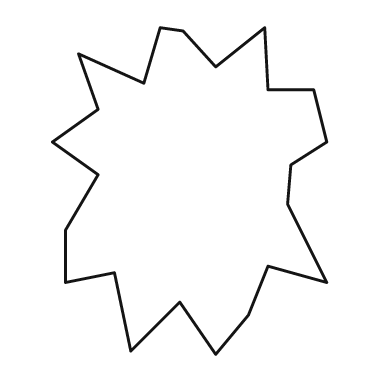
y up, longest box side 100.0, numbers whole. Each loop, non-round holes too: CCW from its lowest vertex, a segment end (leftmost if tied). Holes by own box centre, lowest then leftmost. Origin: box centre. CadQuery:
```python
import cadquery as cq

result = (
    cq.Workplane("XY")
    .moveTo(8.0, -50.0)
    .lineTo(18.0, -38.0)
    .lineTo(24.0, -23.0)
    .lineTo(42.0, -28.0)
    .lineTo(30.0, -4.0)
    .lineTo(31.0, 8.0)
    .lineTo(42.0, 15.0)
    .lineTo(38.0, 31.0)
    .lineTo(24.0, 31.0)
    .lineTo(23.0, 50.0)
    .lineTo(8.0, 38.0)
    .lineTo(-2.0, 49.0)
    .lineTo(-9.0, 50.0)
    .lineTo(-14.0, 33.0)
    .lineTo(-34.0, 42.0)
    .lineTo(-28.0, 25.0)
    .lineTo(-42.0, 15.0)
    .lineTo(-28.0, 5.0)
    .lineTo(-38.0, -12.0)
    .lineTo(-38.0, -28.0)
    .lineTo(-23.0, -25.0)
    .lineTo(-18.0, -49.0)
    .lineTo(-3.0, -34.0)
    .close()
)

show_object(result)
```